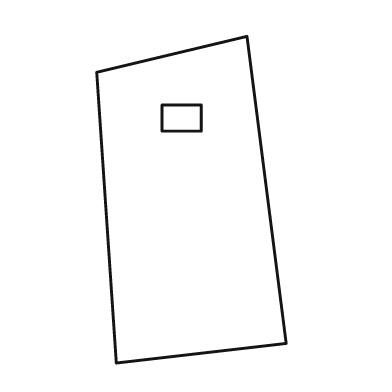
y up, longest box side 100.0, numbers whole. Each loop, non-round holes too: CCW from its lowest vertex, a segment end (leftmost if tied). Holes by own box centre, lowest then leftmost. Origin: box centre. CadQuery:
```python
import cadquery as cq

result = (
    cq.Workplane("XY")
    .moveTo(-23.0, -50.0)
    .lineTo(29.0, -44.0)
    .lineTo(17.0, 50.0)
    .lineTo(-29.0, 39.0)
    .close()
    .moveTo(-9.0, 21.0)
    .lineTo(3.0, 21.0)
    .lineTo(3.0, 29.0)
    .lineTo(-9.0, 29.0)
    .close()
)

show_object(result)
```